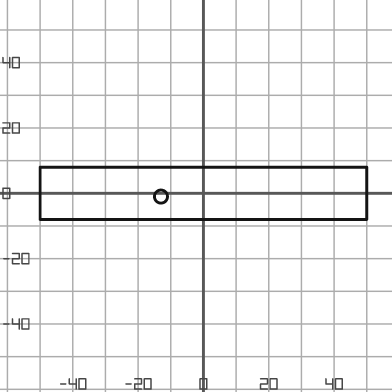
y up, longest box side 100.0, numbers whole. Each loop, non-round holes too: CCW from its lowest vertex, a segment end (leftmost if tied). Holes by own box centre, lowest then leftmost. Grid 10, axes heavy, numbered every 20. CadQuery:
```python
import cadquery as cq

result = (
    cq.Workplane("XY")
    .moveTo(-50.0, -8.0)
    .lineTo(50.0, -8.0)
    .lineTo(50.0, 8.0)
    .lineTo(-50.0, 8.0)
    .close()
    .moveTo(-13.0, -1.0)
    .circle(2.0)
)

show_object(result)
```